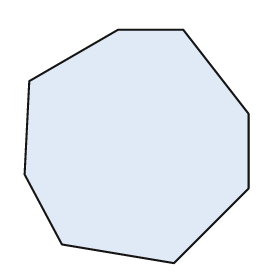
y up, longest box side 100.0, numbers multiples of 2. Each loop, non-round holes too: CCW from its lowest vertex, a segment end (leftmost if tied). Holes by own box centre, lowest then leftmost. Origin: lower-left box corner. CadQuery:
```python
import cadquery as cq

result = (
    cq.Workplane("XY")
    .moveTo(64.0, 0.0)
    .lineTo(96.0, 32.0)
    .lineTo(96.0, 64.0)
    .lineTo(68.0, 100.0)
    .lineTo(40.0, 100.0)
    .lineTo(2.0, 78.0)
    .lineTo(0.0, 38.0)
    .lineTo(16.0, 8.0)
    .close()
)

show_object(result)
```